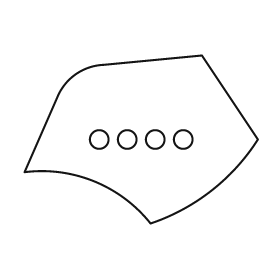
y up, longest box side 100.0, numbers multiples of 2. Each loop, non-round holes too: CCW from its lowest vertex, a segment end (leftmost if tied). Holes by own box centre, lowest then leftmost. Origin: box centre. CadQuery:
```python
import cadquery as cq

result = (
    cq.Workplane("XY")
    .moveTo(4.0, -36.0)
    .threePointArc((30.0, -22.0), (50.0, 0.0))
    .lineTo(26.0, 36.0)
    .lineTo(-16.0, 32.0)
    .threePointArc((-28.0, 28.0), (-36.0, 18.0))
    .lineTo(-50.0, -14.0)
    .threePointArc((-20.0, -18.0), (4.0, -36.0))
    .close()
    .moveTo(-18.0, 0.0)
    .circle(4.0)
    .moveTo(-6.0, 0.0)
    .circle(4.0)
    .moveTo(6.0, 0.0)
    .circle(4.0)
    .moveTo(18.0, 0.0)
    .circle(4.0)
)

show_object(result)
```